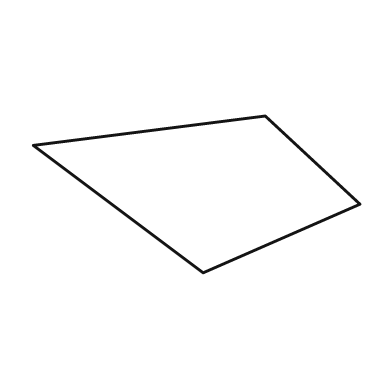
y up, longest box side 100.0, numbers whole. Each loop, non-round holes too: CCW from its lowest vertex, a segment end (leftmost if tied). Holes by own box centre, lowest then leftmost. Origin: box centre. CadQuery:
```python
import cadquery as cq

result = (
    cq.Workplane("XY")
    .moveTo(2.0, -24.0)
    .lineTo(50.0, -3.0)
    .lineTo(21.0, 24.0)
    .lineTo(-50.0, 15.0)
    .close()
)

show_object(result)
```